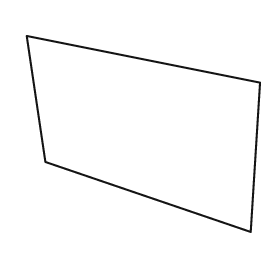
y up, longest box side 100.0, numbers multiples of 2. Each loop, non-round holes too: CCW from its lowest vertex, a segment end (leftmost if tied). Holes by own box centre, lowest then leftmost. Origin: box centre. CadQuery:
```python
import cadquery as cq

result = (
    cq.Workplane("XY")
    .moveTo(46.0, -42.0)
    .lineTo(50.0, 22.0)
    .lineTo(-50.0, 42.0)
    .lineTo(-42.0, -12.0)
    .close()
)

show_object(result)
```